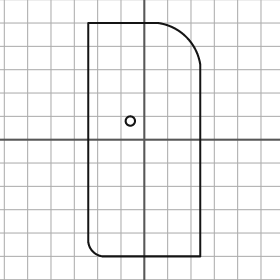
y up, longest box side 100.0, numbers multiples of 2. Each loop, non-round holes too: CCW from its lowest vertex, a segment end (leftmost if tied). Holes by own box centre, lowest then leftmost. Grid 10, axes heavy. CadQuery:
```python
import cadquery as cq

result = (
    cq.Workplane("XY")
    .moveTo(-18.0, -50.0)
    .lineTo(24.0, -50.0)
    .lineTo(24.0, 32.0)
    .threePointArc((18.0, 44.0), (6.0, 50.0))
    .lineTo(-24.0, 50.0)
    .lineTo(-24.0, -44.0)
    .threePointArc((-22.0, -48.0), (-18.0, -50.0))
    .close()
    .moveTo(-6.0, 8.0)
    .circle(2.0)
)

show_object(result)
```